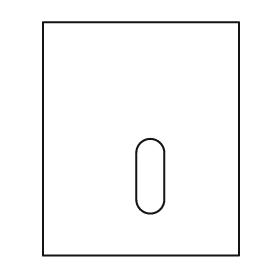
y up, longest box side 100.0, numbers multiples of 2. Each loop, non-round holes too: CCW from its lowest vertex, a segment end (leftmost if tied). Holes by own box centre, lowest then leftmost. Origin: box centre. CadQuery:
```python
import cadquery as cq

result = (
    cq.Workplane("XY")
    .moveTo(-42.0, -50.0)
    .lineTo(42.0, -50.0)
    .lineTo(42.0, 50.0)
    .lineTo(-42.0, 50.0)
    .close()
    .moveTo(-2.0, -26.0)
    .threePointArc((4.0, -32.0), (10.0, -26.0))
    .lineTo(10.0, -6.0)
    .threePointArc((4.0, 0.0), (-2.0, -6.0))
    .close()
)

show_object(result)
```